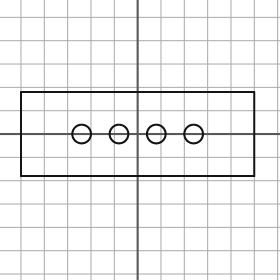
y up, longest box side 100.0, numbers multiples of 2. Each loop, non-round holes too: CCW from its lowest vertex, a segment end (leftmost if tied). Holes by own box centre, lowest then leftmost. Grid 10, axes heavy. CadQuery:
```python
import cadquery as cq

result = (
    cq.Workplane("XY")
    .moveTo(-50.0, -18.0)
    .lineTo(50.0, -18.0)
    .lineTo(50.0, 18.0)
    .lineTo(-50.0, 18.0)
    .close()
    .moveTo(-24.0, 0.0)
    .circle(4.0)
    .moveTo(-8.0, 0.0)
    .circle(4.0)
    .moveTo(8.0, 0.0)
    .circle(4.0)
    .moveTo(24.0, 0.0)
    .circle(4.0)
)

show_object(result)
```